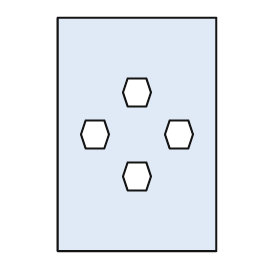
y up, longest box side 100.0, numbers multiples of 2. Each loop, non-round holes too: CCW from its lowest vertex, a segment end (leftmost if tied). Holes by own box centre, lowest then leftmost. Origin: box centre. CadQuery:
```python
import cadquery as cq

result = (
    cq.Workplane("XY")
    .moveTo(-34.0, -50.0)
    .lineTo(34.0, -50.0)
    .lineTo(34.0, 50.0)
    .lineTo(-34.0, 50.0)
    .close()
    .moveTo(-4.0, -24.0)
    .lineTo(4.0, -24.0)
    .lineTo(6.0, -18.0)
    .lineTo(4.0, -12.0)
    .lineTo(-4.0, -12.0)
    .lineTo(-6.0, -18.0)
    .close()
    .moveTo(-22.0, -6.0)
    .lineTo(-14.0, -6.0)
    .lineTo(-12.0, 0.0)
    .lineTo(-14.0, 6.0)
    .lineTo(-22.0, 6.0)
    .lineTo(-24.0, 0.0)
    .close()
    .moveTo(14.0, -6.0)
    .lineTo(22.0, -6.0)
    .lineTo(24.0, 0.0)
    .lineTo(22.0, 6.0)
    .lineTo(14.0, 6.0)
    .lineTo(12.0, 0.0)
    .close()
    .moveTo(-4.0, 12.0)
    .lineTo(4.0, 12.0)
    .lineTo(6.0, 18.0)
    .lineTo(4.0, 24.0)
    .lineTo(-4.0, 24.0)
    .lineTo(-6.0, 18.0)
    .close()
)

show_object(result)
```